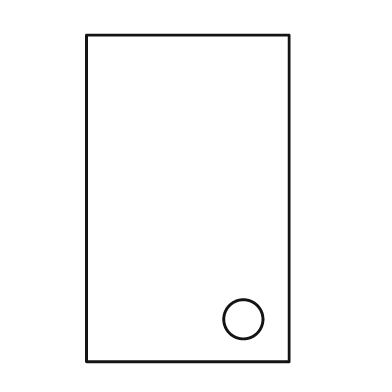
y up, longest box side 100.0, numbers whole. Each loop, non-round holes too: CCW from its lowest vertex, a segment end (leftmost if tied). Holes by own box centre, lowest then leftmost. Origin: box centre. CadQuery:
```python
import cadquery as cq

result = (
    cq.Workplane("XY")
    .moveTo(-31.0, -50.0)
    .lineTo(31.0, -50.0)
    .lineTo(31.0, 50.0)
    .lineTo(-31.0, 50.0)
    .close()
    .moveTo(17.0, -37.0)
    .circle(6.0)
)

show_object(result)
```